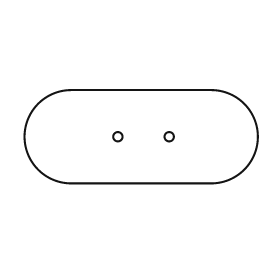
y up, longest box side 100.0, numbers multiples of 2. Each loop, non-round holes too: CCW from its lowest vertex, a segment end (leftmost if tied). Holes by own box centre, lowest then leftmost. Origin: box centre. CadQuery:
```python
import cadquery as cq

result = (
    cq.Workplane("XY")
    .moveTo(-30.0, -20.0)
    .lineTo(30.0, -20.0)
    .threePointArc((50.0, 0.0), (30.0, 20.0))
    .lineTo(-30.0, 20.0)
    .threePointArc((-50.0, 0.0), (-30.0, -20.0))
    .close()
    .moveTo(-10.0, 0.0)
    .circle(2.0)
    .moveTo(12.0, 0.0)
    .circle(2.0)
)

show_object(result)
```